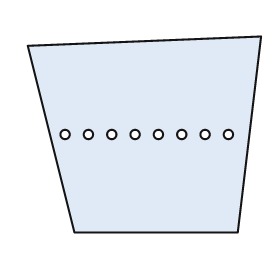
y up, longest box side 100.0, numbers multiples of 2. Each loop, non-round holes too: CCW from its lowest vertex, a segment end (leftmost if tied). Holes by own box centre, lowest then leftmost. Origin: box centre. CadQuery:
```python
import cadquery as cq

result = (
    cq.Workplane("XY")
    .moveTo(-30.0, -42.0)
    .lineTo(40.0, -42.0)
    .lineTo(50.0, 42.0)
    .lineTo(-50.0, 38.0)
    .close()
    .moveTo(-34.0, 0.0)
    .circle(2.0)
    .moveTo(-24.0, 0.0)
    .circle(2.0)
    .moveTo(-14.0, 0.0)
    .circle(2.0)
    .moveTo(-4.0, 0.0)
    .circle(2.0)
    .moveTo(6.0, 0.0)
    .circle(2.0)
    .moveTo(16.0, 0.0)
    .circle(2.0)
    .moveTo(26.0, 0.0)
    .circle(2.0)
    .moveTo(36.0, 0.0)
    .circle(2.0)
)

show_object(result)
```